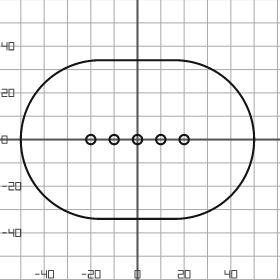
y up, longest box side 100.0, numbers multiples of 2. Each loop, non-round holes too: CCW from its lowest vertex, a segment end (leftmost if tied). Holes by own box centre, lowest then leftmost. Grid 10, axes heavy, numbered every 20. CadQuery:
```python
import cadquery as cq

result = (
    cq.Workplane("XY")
    .moveTo(-16.0, -34.0)
    .lineTo(16.0, -34.0)
    .threePointArc((50.0, 0.0), (16.0, 34.0))
    .lineTo(-16.0, 34.0)
    .threePointArc((-50.0, 0.0), (-16.0, -34.0))
    .close()
    .moveTo(-20.0, 0.0)
    .circle(2.0)
    .moveTo(-10.0, 0.0)
    .circle(2.0)
    .moveTo(0.0, 0.0)
    .circle(2.0)
    .moveTo(10.0, 0.0)
    .circle(2.0)
    .moveTo(20.0, 0.0)
    .circle(2.0)
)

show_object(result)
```